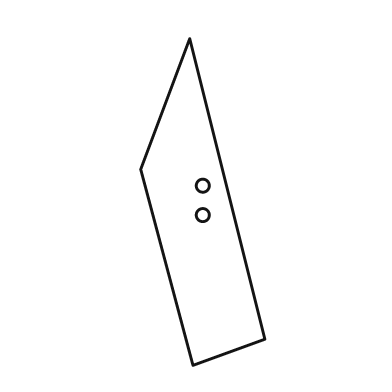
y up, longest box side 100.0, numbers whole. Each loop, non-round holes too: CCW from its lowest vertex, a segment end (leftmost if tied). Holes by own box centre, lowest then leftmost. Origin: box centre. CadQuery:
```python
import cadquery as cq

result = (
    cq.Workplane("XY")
    .moveTo(-3.0, -50.0)
    .lineTo(19.0, -42.0)
    .lineTo(-4.0, 50.0)
    .lineTo(-19.0, 10.0)
    .close()
    .moveTo(0.0, -4.0)
    .circle(2.0)
    .moveTo(0.0, 5.0)
    .circle(2.0)
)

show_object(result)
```